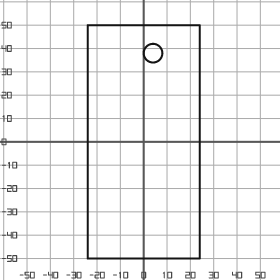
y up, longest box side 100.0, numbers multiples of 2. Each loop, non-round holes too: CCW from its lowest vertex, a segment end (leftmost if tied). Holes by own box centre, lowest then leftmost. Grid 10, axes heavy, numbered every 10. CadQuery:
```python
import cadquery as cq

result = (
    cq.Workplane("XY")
    .moveTo(-24.0, -50.0)
    .lineTo(24.0, -50.0)
    .lineTo(24.0, 50.0)
    .lineTo(-24.0, 50.0)
    .close()
    .moveTo(4.0, 38.0)
    .circle(4.0)
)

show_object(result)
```